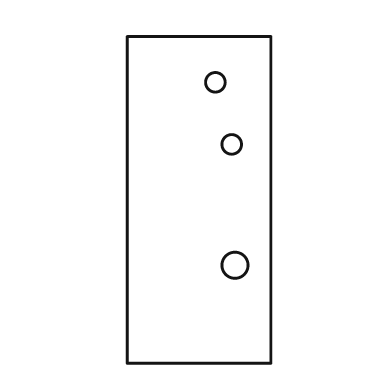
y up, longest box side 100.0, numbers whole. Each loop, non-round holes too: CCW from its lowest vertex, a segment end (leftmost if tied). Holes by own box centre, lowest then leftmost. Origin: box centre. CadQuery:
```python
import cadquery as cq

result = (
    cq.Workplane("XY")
    .moveTo(-22.0, -50.0)
    .lineTo(22.0, -50.0)
    .lineTo(22.0, 50.0)
    .lineTo(-22.0, 50.0)
    .close()
    .moveTo(11.0, -20.0)
    .circle(4.0)
    .moveTo(10.0, 17.0)
    .circle(3.0)
    .moveTo(5.0, 36.0)
    .circle(3.0)
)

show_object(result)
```